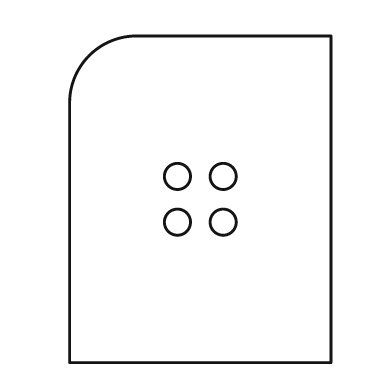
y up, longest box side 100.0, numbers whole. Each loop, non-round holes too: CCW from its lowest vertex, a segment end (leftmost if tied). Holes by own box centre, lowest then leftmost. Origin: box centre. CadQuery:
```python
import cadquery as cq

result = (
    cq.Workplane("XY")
    .moveTo(-40.0, -50.0)
    .lineTo(40.0, -50.0)
    .lineTo(40.0, 50.0)
    .lineTo(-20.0, 50.0)
    .threePointArc((-34.0, 44.0), (-40.0, 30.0))
    .close()
    .moveTo(-7.0, -7.0)
    .circle(4.0)
    .moveTo(7.0, -7.0)
    .circle(4.0)
    .moveTo(-7.0, 7.0)
    .circle(4.0)
    .moveTo(7.0, 7.0)
    .circle(4.0)
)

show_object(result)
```